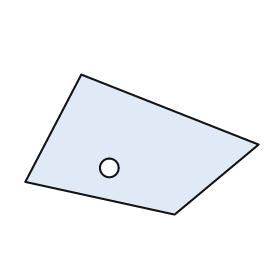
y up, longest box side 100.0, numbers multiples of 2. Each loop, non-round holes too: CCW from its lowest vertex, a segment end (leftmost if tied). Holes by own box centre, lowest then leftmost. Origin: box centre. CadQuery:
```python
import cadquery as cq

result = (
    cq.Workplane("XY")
    .moveTo(14.0, -30.0)
    .lineTo(50.0, 0.0)
    .lineTo(-26.0, 30.0)
    .lineTo(-50.0, -16.0)
    .close()
    .moveTo(-14.0, -10.0)
    .circle(4.0)
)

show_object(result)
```